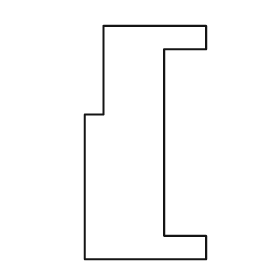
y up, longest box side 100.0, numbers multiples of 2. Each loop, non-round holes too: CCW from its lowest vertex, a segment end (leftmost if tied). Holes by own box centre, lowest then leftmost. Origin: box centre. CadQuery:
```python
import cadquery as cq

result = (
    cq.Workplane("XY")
    .moveTo(-26.0, -50.0)
    .lineTo(26.0, -50.0)
    .lineTo(26.0, -40.0)
    .lineTo(8.0, -40.0)
    .lineTo(8.0, 40.0)
    .lineTo(26.0, 40.0)
    .lineTo(26.0, 50.0)
    .lineTo(-18.0, 50.0)
    .lineTo(-18.0, 12.0)
    .lineTo(-26.0, 12.0)
    .close()
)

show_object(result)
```